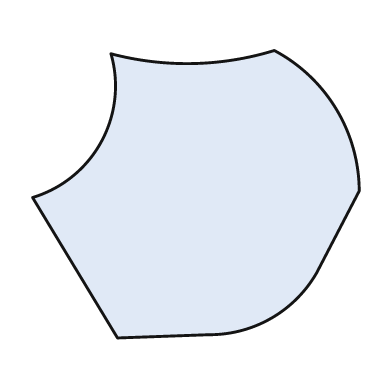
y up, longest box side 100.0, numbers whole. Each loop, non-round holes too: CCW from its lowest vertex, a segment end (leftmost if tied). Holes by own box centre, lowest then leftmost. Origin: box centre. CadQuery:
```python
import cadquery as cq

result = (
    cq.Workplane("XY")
    .moveTo(-24.0, -44.0)
    .lineTo(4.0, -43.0)
    .threePointArc((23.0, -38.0), (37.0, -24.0))
    .lineTo(50.0, 1.0)
    .threePointArc((43.0, 26.0), (24.0, 44.0))
    .threePointArc((-1.0, 40.0), (-26.0, 43.0))
    .threePointArc((-29.0, 16.0), (-50.0, -1.0))
    .close()
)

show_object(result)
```